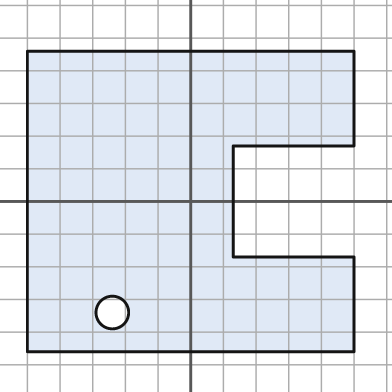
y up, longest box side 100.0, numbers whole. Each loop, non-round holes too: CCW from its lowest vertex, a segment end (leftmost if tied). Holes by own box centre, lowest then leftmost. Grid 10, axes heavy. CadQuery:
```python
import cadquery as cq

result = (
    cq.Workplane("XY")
    .moveTo(-50.0, -46.0)
    .lineTo(50.0, -46.0)
    .lineTo(50.0, -17.0)
    .lineTo(13.0, -17.0)
    .lineTo(13.0, 17.0)
    .lineTo(50.0, 17.0)
    .lineTo(50.0, 46.0)
    .lineTo(-50.0, 46.0)
    .close()
    .moveTo(-24.0, -34.0)
    .circle(5.0)
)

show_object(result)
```